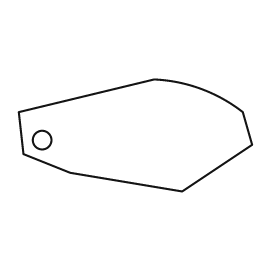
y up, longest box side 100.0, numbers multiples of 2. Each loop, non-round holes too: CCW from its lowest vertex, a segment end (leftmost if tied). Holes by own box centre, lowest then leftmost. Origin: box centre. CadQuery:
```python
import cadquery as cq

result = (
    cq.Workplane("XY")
    .moveTo(20.0, -24.0)
    .lineTo(50.0, -4.0)
    .lineTo(46.0, 10.0)
    .threePointArc((28.0, 20.0), (8.0, 24.0))
    .lineTo(-50.0, 10.0)
    .lineTo(-48.0, -8.0)
    .lineTo(-28.0, -16.0)
    .close()
    .moveTo(-40.0, -2.0)
    .circle(4.0)
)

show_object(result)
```